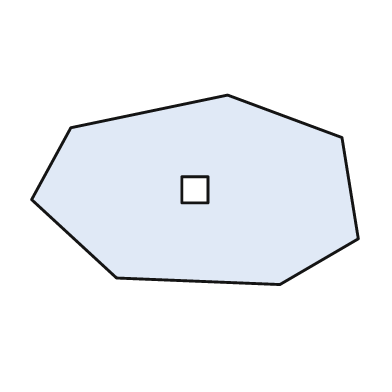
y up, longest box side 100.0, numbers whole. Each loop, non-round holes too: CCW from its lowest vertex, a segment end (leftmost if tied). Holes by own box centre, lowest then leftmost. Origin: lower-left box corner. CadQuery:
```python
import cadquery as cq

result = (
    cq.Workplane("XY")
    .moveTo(76.0, 0.0)
    .lineTo(100.0, 14.0)
    .lineTo(95.0, 45.0)
    .lineTo(60.0, 58.0)
    .lineTo(12.0, 48.0)
    .lineTo(0.0, 26.0)
    .lineTo(26.0, 2.0)
    .close()
    .moveTo(46.0, 25.0)
    .lineTo(54.0, 25.0)
    .lineTo(54.0, 33.0)
    .lineTo(46.0, 33.0)
    .close()
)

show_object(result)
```